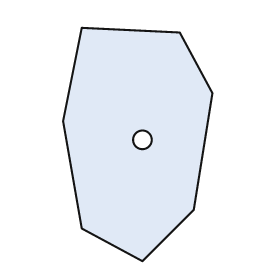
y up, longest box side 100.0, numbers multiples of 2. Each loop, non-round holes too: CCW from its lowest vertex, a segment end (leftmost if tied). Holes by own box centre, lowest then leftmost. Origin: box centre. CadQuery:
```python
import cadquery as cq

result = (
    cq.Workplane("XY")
    .moveTo(2.0, -50.0)
    .lineTo(24.0, -28.0)
    .lineTo(32.0, 22.0)
    .lineTo(18.0, 48.0)
    .lineTo(-24.0, 50.0)
    .lineTo(-32.0, 10.0)
    .lineTo(-24.0, -36.0)
    .close()
    .moveTo(2.0, 2.0)
    .circle(4.0)
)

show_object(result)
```